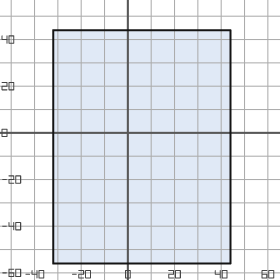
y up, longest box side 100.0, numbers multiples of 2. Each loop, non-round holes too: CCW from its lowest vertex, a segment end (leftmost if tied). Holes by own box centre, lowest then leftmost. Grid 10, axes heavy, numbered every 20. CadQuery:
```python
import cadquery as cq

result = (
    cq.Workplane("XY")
    .moveTo(-32.0, -56.0)
    .lineTo(44.0, -56.0)
    .lineTo(44.0, 44.0)
    .lineTo(-32.0, 44.0)
    .close()
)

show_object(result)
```